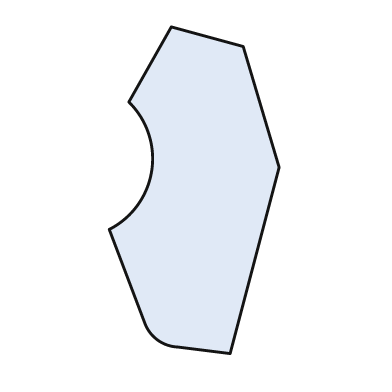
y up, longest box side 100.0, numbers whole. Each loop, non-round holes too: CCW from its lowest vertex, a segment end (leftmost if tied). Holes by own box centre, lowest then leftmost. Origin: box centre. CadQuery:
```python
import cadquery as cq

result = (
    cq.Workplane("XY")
    .moveTo(11.0, -50.0)
    .lineTo(26.0, 7.0)
    .lineTo(15.0, 44.0)
    .lineTo(-7.0, 50.0)
    .lineTo(-20.0, 27.0)
    .threePointArc((-13.0, 6.0), (-26.0, -12.0))
    .lineTo(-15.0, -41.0)
    .threePointArc((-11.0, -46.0), (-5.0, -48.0))
    .close()
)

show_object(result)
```